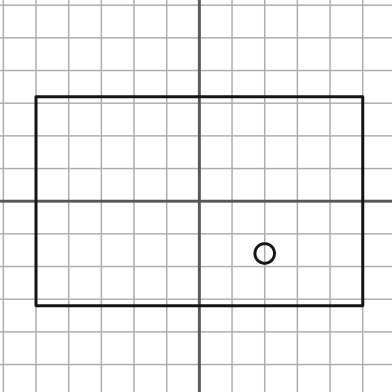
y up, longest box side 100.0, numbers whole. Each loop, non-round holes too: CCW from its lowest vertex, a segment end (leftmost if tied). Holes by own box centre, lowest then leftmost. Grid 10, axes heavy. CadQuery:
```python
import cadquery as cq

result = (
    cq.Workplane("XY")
    .moveTo(-50.0, -32.0)
    .lineTo(50.0, -32.0)
    .lineTo(50.0, 32.0)
    .lineTo(-50.0, 32.0)
    .close()
    .moveTo(20.0, -16.0)
    .circle(3.0)
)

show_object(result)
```